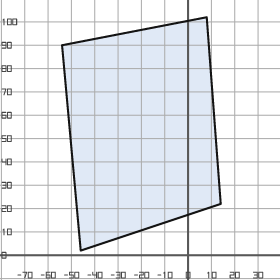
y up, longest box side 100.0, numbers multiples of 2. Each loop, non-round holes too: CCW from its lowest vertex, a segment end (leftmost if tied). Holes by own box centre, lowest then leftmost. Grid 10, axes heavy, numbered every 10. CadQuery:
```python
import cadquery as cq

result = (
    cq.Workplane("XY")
    .moveTo(-46.0, 2.0)
    .lineTo(14.0, 22.0)
    .lineTo(8.0, 102.0)
    .lineTo(-54.0, 90.0)
    .close()
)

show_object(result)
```